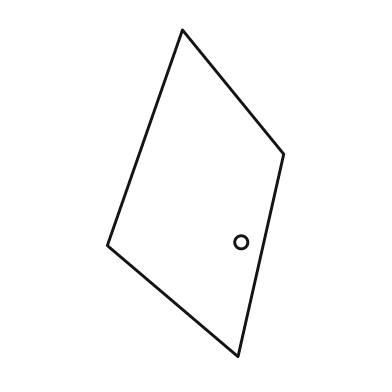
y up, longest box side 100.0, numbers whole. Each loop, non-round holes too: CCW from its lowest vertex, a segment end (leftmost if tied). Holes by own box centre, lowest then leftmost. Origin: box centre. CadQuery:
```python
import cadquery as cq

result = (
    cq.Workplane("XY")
    .moveTo(13.0, -50.0)
    .lineTo(27.0, 12.0)
    .lineTo(-4.0, 50.0)
    .lineTo(-27.0, -16.0)
    .close()
    .moveTo(14.0, -15.0)
    .circle(2.0)
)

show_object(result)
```